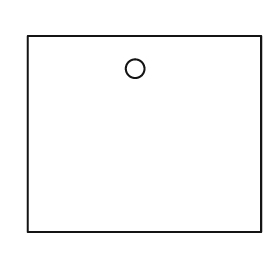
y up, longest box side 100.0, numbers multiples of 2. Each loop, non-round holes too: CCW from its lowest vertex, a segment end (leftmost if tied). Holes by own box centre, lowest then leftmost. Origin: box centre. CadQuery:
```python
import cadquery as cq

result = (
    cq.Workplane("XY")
    .moveTo(-50.0, -42.0)
    .lineTo(50.0, -42.0)
    .lineTo(50.0, 42.0)
    .lineTo(-50.0, 42.0)
    .close()
    .moveTo(-4.0, 28.0)
    .circle(4.0)
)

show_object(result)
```